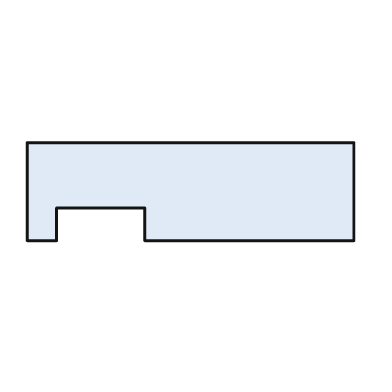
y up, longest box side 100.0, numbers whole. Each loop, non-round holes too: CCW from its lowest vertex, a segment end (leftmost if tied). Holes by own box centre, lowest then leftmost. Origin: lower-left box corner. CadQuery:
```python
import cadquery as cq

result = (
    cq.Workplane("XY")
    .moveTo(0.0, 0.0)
    .lineTo(9.0, 0.0)
    .lineTo(9.0, 10.0)
    .lineTo(36.0, 10.0)
    .lineTo(36.0, 0.0)
    .lineTo(100.0, 0.0)
    .lineTo(100.0, 30.0)
    .lineTo(0.0, 30.0)
    .close()
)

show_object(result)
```